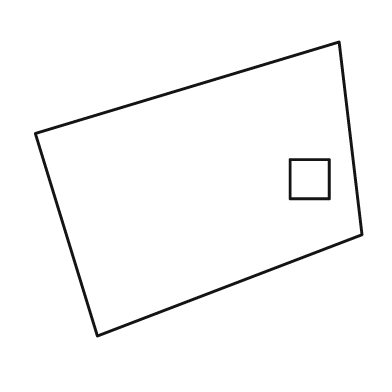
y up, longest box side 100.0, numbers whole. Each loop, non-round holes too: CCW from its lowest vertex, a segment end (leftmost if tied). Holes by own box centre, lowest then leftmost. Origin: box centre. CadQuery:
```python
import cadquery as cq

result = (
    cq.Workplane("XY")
    .moveTo(-31.0, -45.0)
    .lineTo(50.0, -14.0)
    .lineTo(43.0, 45.0)
    .lineTo(-50.0, 17.0)
    .close()
    .moveTo(28.0, -3.0)
    .lineTo(40.0, -3.0)
    .lineTo(40.0, 9.0)
    .lineTo(28.0, 9.0)
    .close()
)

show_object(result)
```